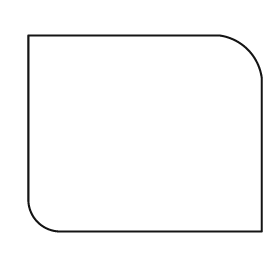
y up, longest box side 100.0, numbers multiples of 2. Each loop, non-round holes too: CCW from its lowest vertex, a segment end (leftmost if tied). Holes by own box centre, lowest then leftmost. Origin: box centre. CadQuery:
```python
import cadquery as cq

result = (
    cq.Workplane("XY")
    .moveTo(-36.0, -42.0)
    .lineTo(50.0, -42.0)
    .lineTo(50.0, 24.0)
    .threePointArc((44.0, 36.0), (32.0, 42.0))
    .lineTo(-50.0, 42.0)
    .lineTo(-50.0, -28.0)
    .threePointArc((-46.0, -38.0), (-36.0, -42.0))
    .close()
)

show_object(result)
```